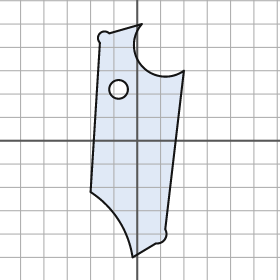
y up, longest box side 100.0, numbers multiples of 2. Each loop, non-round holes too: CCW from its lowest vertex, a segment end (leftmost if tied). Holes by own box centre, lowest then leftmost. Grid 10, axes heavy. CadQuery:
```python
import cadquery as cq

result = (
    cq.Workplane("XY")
    .moveTo(-2.0, -50.0)
    .lineTo(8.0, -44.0)
    .threePointArc((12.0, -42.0), (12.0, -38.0))
    .lineTo(20.0, 30.0)
    .threePointArc((2.0, 32.0), (2.0, 50.0))
    .lineTo(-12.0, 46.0)
    .threePointArc((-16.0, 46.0), (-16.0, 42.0))
    .lineTo(-20.0, -22.0)
    .threePointArc((-8.0, -34.0), (-2.0, -50.0))
    .close()
    .moveTo(-8.0, 22.0)
    .circle(4.0)
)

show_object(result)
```